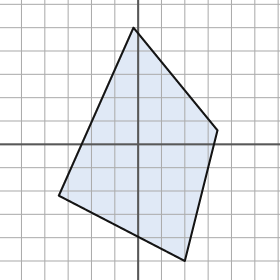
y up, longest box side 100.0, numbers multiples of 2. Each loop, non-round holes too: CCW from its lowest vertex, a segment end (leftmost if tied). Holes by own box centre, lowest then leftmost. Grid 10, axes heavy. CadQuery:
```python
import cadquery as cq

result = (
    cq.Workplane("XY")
    .moveTo(20.0, -50.0)
    .lineTo(34.0, 6.0)
    .lineTo(-2.0, 50.0)
    .lineTo(-34.0, -22.0)
    .close()
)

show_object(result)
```